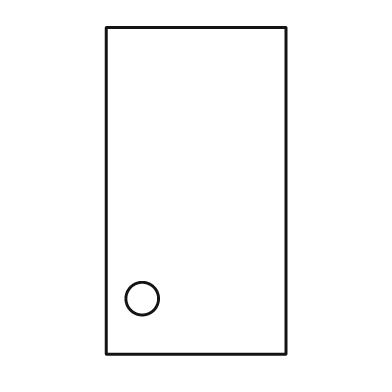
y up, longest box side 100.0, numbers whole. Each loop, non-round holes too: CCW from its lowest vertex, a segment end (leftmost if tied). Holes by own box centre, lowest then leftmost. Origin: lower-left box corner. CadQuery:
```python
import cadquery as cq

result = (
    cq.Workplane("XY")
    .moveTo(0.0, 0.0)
    .lineTo(55.0, 0.0)
    .lineTo(55.0, 100.0)
    .lineTo(0.0, 100.0)
    .close()
    .moveTo(11.0, 17.0)
    .circle(5.0)
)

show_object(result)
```